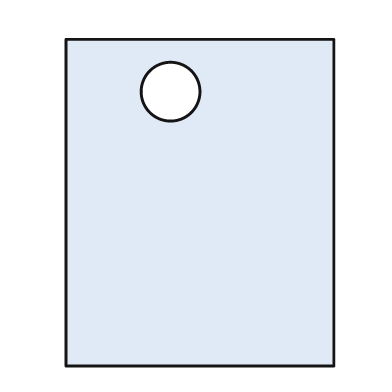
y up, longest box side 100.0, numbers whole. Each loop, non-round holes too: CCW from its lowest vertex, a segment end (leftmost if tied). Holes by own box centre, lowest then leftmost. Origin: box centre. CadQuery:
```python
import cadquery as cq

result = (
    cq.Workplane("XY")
    .moveTo(-41.0, -50.0)
    .lineTo(41.0, -50.0)
    .lineTo(41.0, 50.0)
    .lineTo(-41.0, 50.0)
    .close()
    .moveTo(-9.0, 34.0)
    .circle(9.0)
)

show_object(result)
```